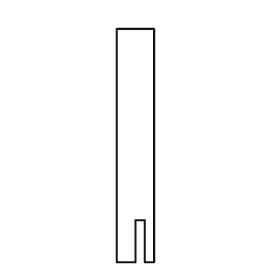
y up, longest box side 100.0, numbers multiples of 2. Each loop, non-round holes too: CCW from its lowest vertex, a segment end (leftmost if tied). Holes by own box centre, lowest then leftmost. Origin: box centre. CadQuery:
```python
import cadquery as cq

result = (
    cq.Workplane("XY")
    .moveTo(-8.0, -50.0)
    .lineTo(0.0, -50.0)
    .lineTo(0.0, -32.0)
    .lineTo(4.0, -32.0)
    .lineTo(4.0, -50.0)
    .lineTo(8.0, -50.0)
    .lineTo(8.0, 50.0)
    .lineTo(-8.0, 50.0)
    .close()
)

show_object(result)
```